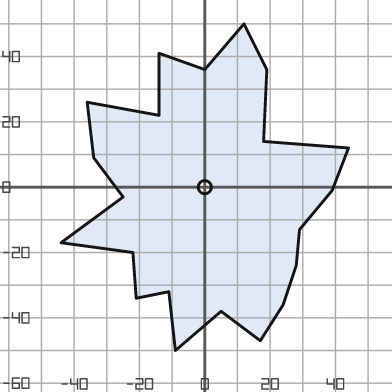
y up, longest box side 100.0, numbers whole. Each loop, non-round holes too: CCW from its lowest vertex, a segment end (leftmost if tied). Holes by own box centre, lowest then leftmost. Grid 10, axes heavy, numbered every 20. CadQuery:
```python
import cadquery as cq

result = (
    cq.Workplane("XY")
    .moveTo(-9.0, -50.0)
    .lineTo(5.0, -38.0)
    .lineTo(17.0, -47.0)
    .lineTo(24.0, -36.0)
    .lineTo(28.0, -24.0)
    .lineTo(29.0, -13.0)
    .lineTo(39.0, -1.0)
    .lineTo(44.0, 12.0)
    .lineTo(18.0, 14.0)
    .lineTo(19.0, 36.0)
    .lineTo(12.0, 50.0)
    .lineTo(0.0, 36.0)
    .lineTo(-14.0, 41.0)
    .lineTo(-14.0, 22.0)
    .lineTo(-36.0, 26.0)
    .lineTo(-34.0, 9.0)
    .lineTo(-25.0, -3.0)
    .lineTo(-44.0, -17.0)
    .lineTo(-22.0, -20.0)
    .lineTo(-21.0, -34.0)
    .lineTo(-11.0, -32.0)
    .close()
    .moveTo(0.0, 0.0)
    .circle(2.0)
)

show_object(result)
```